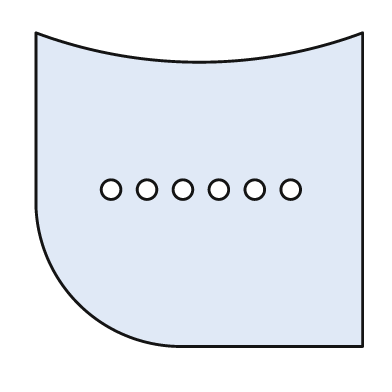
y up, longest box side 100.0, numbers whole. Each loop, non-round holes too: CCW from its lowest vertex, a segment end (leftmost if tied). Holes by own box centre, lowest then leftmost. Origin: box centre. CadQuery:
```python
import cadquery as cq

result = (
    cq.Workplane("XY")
    .moveTo(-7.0, -48.0)
    .lineTo(50.0, -48.0)
    .lineTo(50.0, 48.0)
    .threePointArc((0.0, 39.0), (-50.0, 48.0))
    .lineTo(-50.0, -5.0)
    .threePointArc((-37.0, -35.0), (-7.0, -48.0))
    .close()
    .moveTo(-27.0, 0.0)
    .circle(3.0)
    .moveTo(-16.0, 0.0)
    .circle(3.0)
    .moveTo(-5.0, 0.0)
    .circle(3.0)
    .moveTo(6.0, 0.0)
    .circle(3.0)
    .moveTo(17.0, 0.0)
    .circle(3.0)
    .moveTo(28.0, 0.0)
    .circle(3.0)
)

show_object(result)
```